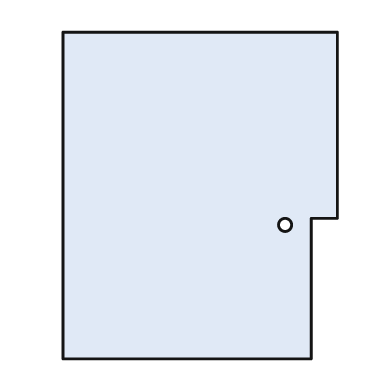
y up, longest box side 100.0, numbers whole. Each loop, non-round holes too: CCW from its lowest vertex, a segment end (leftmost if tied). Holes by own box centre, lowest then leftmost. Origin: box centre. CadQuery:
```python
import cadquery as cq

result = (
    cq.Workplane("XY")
    .moveTo(-42.0, -50.0)
    .lineTo(34.0, -50.0)
    .lineTo(34.0, -7.0)
    .lineTo(42.0, -7.0)
    .lineTo(42.0, 50.0)
    .lineTo(-42.0, 50.0)
    .close()
    .moveTo(26.0, -9.0)
    .circle(2.0)
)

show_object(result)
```